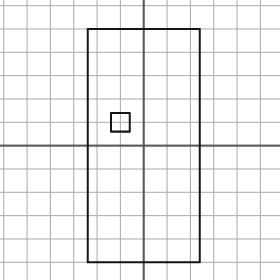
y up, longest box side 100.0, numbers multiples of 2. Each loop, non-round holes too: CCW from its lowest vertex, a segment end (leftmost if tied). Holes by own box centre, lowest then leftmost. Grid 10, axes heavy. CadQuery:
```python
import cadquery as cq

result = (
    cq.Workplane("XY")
    .moveTo(-24.0, -50.0)
    .lineTo(24.0, -50.0)
    .lineTo(24.0, 50.0)
    .lineTo(-24.0, 50.0)
    .close()
    .moveTo(-14.0, 6.0)
    .lineTo(-6.0, 6.0)
    .lineTo(-6.0, 14.0)
    .lineTo(-14.0, 14.0)
    .close()
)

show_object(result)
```